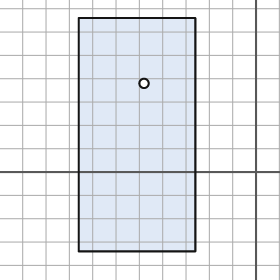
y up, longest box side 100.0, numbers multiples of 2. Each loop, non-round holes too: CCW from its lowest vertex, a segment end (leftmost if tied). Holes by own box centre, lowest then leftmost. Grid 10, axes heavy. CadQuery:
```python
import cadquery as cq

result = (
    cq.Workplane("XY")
    .moveTo(-76.0, -34.0)
    .lineTo(-26.0, -34.0)
    .lineTo(-26.0, 66.0)
    .lineTo(-76.0, 66.0)
    .close()
    .moveTo(-48.0, 38.0)
    .circle(2.0)
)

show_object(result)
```